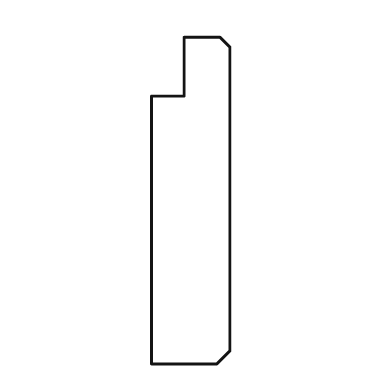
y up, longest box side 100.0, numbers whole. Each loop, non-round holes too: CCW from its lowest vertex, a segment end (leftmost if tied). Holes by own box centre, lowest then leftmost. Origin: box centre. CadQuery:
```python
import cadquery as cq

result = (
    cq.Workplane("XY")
    .moveTo(-12.0, -50.0)
    .lineTo(8.0, -50.0)
    .lineTo(12.0, -46.0)
    .lineTo(12.0, 47.0)
    .lineTo(9.0, 50.0)
    .lineTo(-2.0, 50.0)
    .lineTo(-2.0, 32.0)
    .lineTo(-12.0, 32.0)
    .close()
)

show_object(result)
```